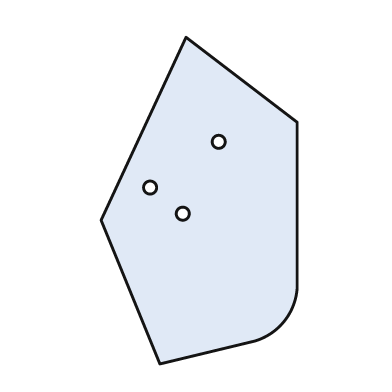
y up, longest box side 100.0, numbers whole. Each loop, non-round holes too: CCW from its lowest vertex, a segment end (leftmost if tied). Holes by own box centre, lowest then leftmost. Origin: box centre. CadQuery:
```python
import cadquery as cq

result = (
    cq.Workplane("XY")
    .moveTo(-12.0, -50.0)
    .lineTo(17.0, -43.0)
    .threePointArc((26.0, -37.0), (30.0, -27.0))
    .lineTo(30.0, 24.0)
    .lineTo(-4.0, 50.0)
    .lineTo(-30.0, -6.0)
    .close()
    .moveTo(-5.0, -4.0)
    .circle(2.0)
    .moveTo(-15.0, 4.0)
    .circle(2.0)
    .moveTo(6.0, 18.0)
    .circle(2.0)
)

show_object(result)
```